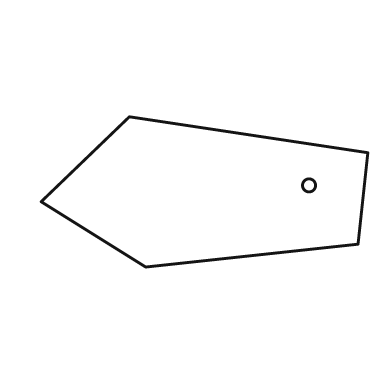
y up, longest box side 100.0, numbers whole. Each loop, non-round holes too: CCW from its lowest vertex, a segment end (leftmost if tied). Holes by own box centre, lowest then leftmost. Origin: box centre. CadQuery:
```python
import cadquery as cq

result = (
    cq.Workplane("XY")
    .moveTo(-18.0, -23.0)
    .lineTo(47.0, -16.0)
    .lineTo(50.0, 12.0)
    .lineTo(-23.0, 23.0)
    .lineTo(-50.0, -3.0)
    .close()
    .moveTo(32.0, 2.0)
    .circle(2.0)
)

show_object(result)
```